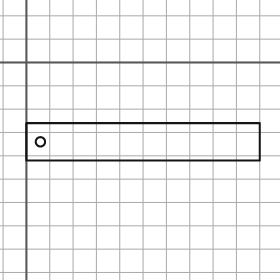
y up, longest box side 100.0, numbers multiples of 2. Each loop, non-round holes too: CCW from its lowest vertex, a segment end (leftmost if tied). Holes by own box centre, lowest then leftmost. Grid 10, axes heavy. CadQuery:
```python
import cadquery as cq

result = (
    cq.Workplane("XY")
    .moveTo(0.0, -42.0)
    .lineTo(100.0, -42.0)
    .lineTo(100.0, -26.0)
    .lineTo(0.0, -26.0)
    .close()
    .moveTo(6.0, -34.0)
    .circle(2.0)
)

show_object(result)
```